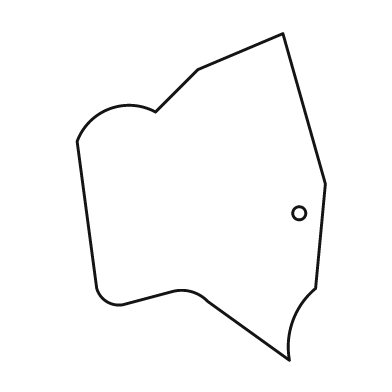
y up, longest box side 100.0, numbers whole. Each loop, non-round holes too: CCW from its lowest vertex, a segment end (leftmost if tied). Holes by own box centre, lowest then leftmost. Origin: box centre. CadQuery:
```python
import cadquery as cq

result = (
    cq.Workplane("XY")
    .moveTo(27.0, -50.0)
    .threePointArc((28.0, -38.0), (35.0, -28.0))
    .lineTo(38.0, 4.0)
    .lineTo(25.0, 50.0)
    .lineTo(-1.0, 39.0)
    .lineTo(-14.0, 26.0)
    .threePointArc((-28.0, 27.0), (-38.0, 17.0))
    .lineTo(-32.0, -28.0)
    .threePointArc((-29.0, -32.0), (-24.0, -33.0))
    .lineTo(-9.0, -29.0)
    .threePointArc((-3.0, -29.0), (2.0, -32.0))
    .close()
    .moveTo(30.0, -5.0)
    .circle(2.0)
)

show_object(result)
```